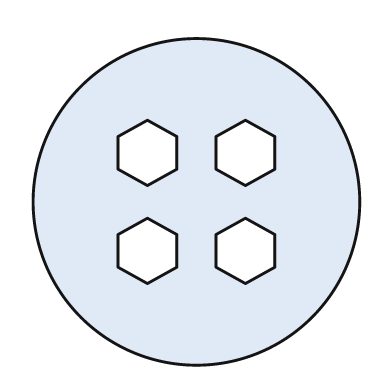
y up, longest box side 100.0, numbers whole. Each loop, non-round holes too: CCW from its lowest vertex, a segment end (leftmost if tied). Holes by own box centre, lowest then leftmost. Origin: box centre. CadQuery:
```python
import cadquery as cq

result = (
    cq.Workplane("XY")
    .moveTo(0.0, 0.0)
    .circle(50.0)
    .moveTo(-15.0, -25.0)
    .lineTo(-6.0, -20.0)
    .lineTo(-6.0, -10.0)
    .lineTo(-15.0, -5.0)
    .lineTo(-24.0, -10.0)
    .lineTo(-24.0, -20.0)
    .close()
    .moveTo(15.0, -25.0)
    .lineTo(24.0, -20.0)
    .lineTo(24.0, -10.0)
    .lineTo(15.0, -5.0)
    .lineTo(6.0, -10.0)
    .lineTo(6.0, -20.0)
    .close()
    .moveTo(-15.0, 5.0)
    .lineTo(-6.0, 10.0)
    .lineTo(-6.0, 20.0)
    .lineTo(-15.0, 25.0)
    .lineTo(-24.0, 20.0)
    .lineTo(-24.0, 10.0)
    .close()
    .moveTo(15.0, 5.0)
    .lineTo(24.0, 10.0)
    .lineTo(24.0, 20.0)
    .lineTo(15.0, 25.0)
    .lineTo(6.0, 20.0)
    .lineTo(6.0, 10.0)
    .close()
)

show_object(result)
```